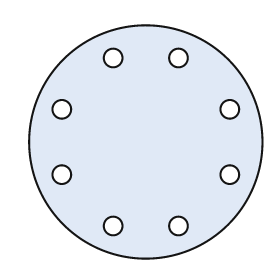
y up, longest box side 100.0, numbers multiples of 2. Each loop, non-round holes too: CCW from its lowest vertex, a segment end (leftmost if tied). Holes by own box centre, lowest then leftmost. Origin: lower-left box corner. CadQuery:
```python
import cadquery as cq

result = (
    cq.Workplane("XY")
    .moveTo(50.0, 50.0)
    .circle(50.0)
    .moveTo(36.0, 14.0)
    .circle(4.0)
    .moveTo(64.0, 14.0)
    .circle(4.0)
    .moveTo(14.0, 36.0)
    .circle(4.0)
    .moveTo(86.0, 36.0)
    .circle(4.0)
    .moveTo(14.0, 64.0)
    .circle(4.0)
    .moveTo(86.0, 64.0)
    .circle(4.0)
    .moveTo(36.0, 86.0)
    .circle(4.0)
    .moveTo(64.0, 86.0)
    .circle(4.0)
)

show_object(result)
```